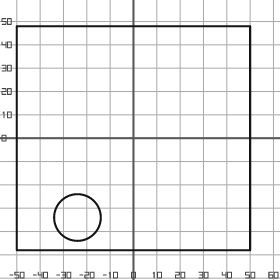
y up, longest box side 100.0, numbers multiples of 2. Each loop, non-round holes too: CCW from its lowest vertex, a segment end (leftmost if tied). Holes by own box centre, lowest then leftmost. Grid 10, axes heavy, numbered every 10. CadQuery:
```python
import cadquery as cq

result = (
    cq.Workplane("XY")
    .moveTo(-50.0, -48.0)
    .lineTo(50.0, -48.0)
    .lineTo(50.0, 48.0)
    .lineTo(-50.0, 48.0)
    .close()
    .moveTo(-24.0, -34.0)
    .circle(10.0)
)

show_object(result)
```